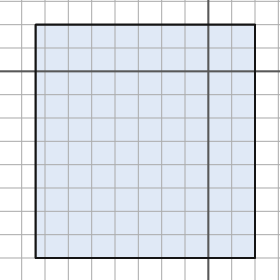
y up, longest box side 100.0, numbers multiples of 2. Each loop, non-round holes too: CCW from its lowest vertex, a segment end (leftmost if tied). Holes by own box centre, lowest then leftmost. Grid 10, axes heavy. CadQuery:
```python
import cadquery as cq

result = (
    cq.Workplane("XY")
    .moveTo(-74.0, -80.0)
    .lineTo(20.0, -80.0)
    .lineTo(20.0, 20.0)
    .lineTo(-74.0, 20.0)
    .close()
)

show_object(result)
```